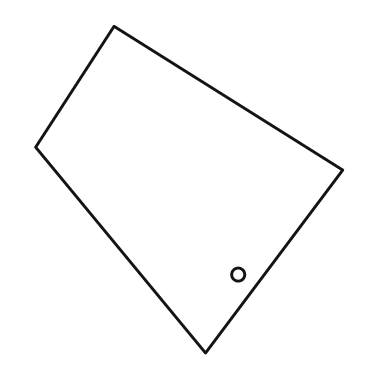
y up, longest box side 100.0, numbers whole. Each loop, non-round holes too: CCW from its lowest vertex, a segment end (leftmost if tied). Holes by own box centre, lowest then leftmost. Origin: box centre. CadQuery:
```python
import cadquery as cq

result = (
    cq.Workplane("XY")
    .moveTo(5.0, -50.0)
    .lineTo(47.0, 6.0)
    .lineTo(-23.0, 50.0)
    .lineTo(-47.0, 13.0)
    .close()
    .moveTo(15.0, -26.0)
    .circle(2.0)
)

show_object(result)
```